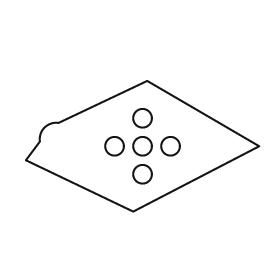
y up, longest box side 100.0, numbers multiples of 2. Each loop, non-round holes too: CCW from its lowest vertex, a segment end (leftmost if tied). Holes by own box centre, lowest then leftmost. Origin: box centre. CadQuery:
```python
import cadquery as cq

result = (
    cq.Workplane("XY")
    .moveTo(-4.0, -28.0)
    .lineTo(50.0, 0.0)
    .lineTo(2.0, 28.0)
    .lineTo(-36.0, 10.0)
    .threePointArc((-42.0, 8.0), (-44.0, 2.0))
    .lineTo(-50.0, -6.0)
    .close()
    .moveTo(0.0, -12.0)
    .circle(4.0)
    .moveTo(-12.0, 0.0)
    .circle(4.0)
    .moveTo(0.0, 0.0)
    .circle(4.0)
    .moveTo(12.0, 0.0)
    .circle(4.0)
    .moveTo(0.0, 12.0)
    .circle(4.0)
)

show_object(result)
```